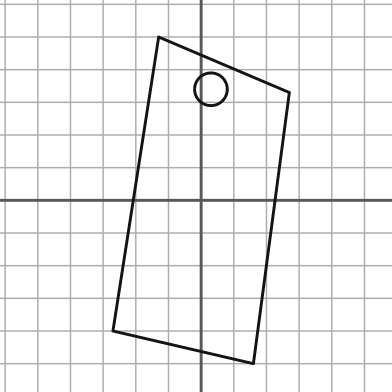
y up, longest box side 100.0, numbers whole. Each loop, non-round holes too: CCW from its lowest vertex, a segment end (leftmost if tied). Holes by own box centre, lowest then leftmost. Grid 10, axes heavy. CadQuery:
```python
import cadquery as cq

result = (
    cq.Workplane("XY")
    .moveTo(16.0, -50.0)
    .lineTo(27.0, 33.0)
    .lineTo(-13.0, 50.0)
    .lineTo(-27.0, -40.0)
    .close()
    .moveTo(3.0, 34.0)
    .circle(5.0)
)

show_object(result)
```